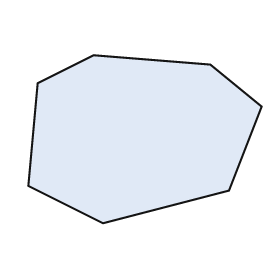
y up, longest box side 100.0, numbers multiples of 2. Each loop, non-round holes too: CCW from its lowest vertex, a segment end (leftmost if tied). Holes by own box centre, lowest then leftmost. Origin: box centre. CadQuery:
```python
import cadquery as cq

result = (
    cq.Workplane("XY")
    .moveTo(-18.0, -36.0)
    .lineTo(36.0, -22.0)
    .lineTo(50.0, 14.0)
    .lineTo(28.0, 32.0)
    .lineTo(-22.0, 36.0)
    .lineTo(-46.0, 24.0)
    .lineTo(-50.0, -20.0)
    .close()
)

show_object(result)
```